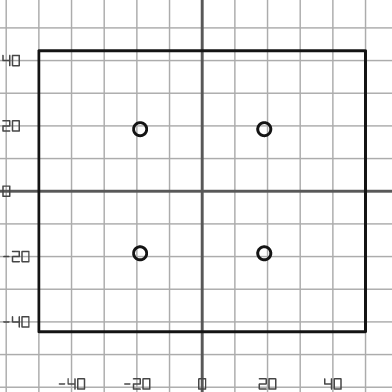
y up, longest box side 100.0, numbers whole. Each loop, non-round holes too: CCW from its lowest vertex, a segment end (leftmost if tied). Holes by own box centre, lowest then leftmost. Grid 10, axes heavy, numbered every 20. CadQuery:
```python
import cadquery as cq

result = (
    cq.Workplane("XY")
    .moveTo(-50.0, -43.0)
    .lineTo(50.0, -43.0)
    .lineTo(50.0, 43.0)
    .lineTo(-50.0, 43.0)
    .close()
    .moveTo(-19.0, -19.0)
    .circle(2.0)
    .moveTo(19.0, -19.0)
    .circle(2.0)
    .moveTo(-19.0, 19.0)
    .circle(2.0)
    .moveTo(19.0, 19.0)
    .circle(2.0)
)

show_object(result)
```